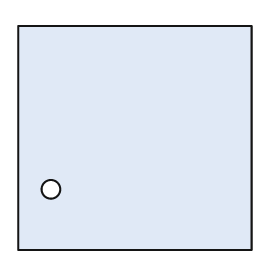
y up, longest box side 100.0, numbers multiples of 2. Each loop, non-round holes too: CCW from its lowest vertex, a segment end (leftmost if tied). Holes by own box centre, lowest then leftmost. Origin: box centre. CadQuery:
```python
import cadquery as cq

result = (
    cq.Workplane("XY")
    .moveTo(-50.0, -48.0)
    .lineTo(50.0, -48.0)
    .lineTo(50.0, 48.0)
    .lineTo(-50.0, 48.0)
    .close()
    .moveTo(-36.0, -22.0)
    .circle(4.0)
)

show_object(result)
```